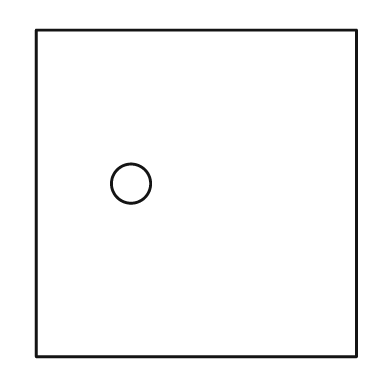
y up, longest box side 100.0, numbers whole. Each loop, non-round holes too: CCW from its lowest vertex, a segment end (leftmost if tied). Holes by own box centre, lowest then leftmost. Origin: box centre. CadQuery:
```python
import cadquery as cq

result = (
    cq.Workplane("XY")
    .moveTo(-49.0, -50.0)
    .lineTo(49.0, -50.0)
    .lineTo(49.0, 50.0)
    .lineTo(-49.0, 50.0)
    .close()
    .moveTo(-20.0, 3.0)
    .circle(6.0)
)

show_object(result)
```